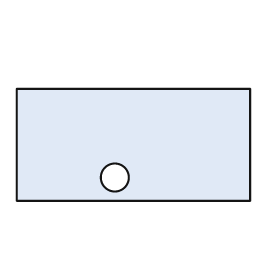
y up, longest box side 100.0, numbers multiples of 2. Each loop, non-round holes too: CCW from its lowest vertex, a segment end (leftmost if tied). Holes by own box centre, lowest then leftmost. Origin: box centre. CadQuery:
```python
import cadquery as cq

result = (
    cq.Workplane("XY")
    .moveTo(-50.0, -24.0)
    .lineTo(50.0, -24.0)
    .lineTo(50.0, 24.0)
    .lineTo(-50.0, 24.0)
    .close()
    .moveTo(-8.0, -14.0)
    .circle(6.0)
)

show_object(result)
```